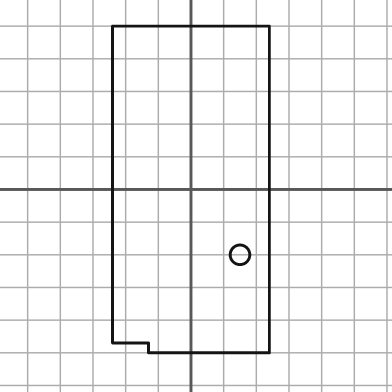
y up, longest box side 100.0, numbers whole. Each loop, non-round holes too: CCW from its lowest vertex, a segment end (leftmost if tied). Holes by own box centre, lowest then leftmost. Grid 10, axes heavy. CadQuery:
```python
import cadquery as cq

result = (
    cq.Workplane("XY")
    .moveTo(-13.0, -50.0)
    .lineTo(24.0, -50.0)
    .lineTo(24.0, 50.0)
    .lineTo(-24.0, 50.0)
    .lineTo(-24.0, -47.0)
    .lineTo(-13.0, -47.0)
    .close()
    .moveTo(15.0, -20.0)
    .circle(3.0)
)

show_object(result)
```